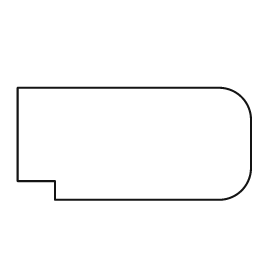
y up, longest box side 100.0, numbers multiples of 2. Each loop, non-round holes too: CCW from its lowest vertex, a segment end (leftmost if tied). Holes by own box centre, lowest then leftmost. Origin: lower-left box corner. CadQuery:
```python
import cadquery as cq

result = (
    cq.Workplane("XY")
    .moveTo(16.0, 0.0)
    .lineTo(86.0, 0.0)
    .threePointArc((96.0, 4.0), (100.0, 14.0))
    .lineTo(100.0, 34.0)
    .threePointArc((96.0, 44.0), (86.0, 48.0))
    .lineTo(0.0, 48.0)
    .lineTo(0.0, 8.0)
    .lineTo(16.0, 8.0)
    .close()
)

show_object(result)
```